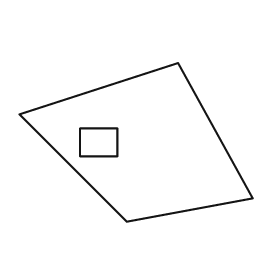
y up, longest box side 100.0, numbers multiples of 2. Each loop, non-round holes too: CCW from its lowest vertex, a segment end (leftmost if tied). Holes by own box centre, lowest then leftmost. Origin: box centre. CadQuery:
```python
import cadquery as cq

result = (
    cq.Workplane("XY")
    .moveTo(-4.0, -34.0)
    .lineTo(50.0, -24.0)
    .lineTo(18.0, 34.0)
    .lineTo(-50.0, 12.0)
    .close()
    .moveTo(-24.0, -6.0)
    .lineTo(-8.0, -6.0)
    .lineTo(-8.0, 6.0)
    .lineTo(-24.0, 6.0)
    .close()
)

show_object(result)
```